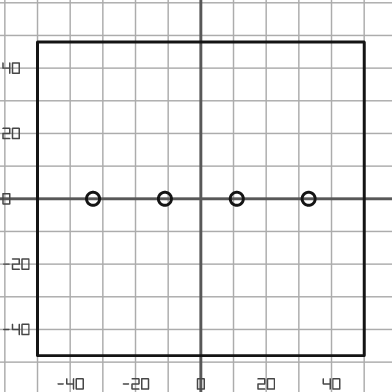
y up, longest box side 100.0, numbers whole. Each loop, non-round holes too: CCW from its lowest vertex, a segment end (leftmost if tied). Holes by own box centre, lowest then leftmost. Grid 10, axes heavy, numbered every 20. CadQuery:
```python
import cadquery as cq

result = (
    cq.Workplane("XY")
    .moveTo(-50.0, -48.0)
    .lineTo(50.0, -48.0)
    .lineTo(50.0, 48.0)
    .lineTo(-50.0, 48.0)
    .close()
    .moveTo(-33.0, 0.0)
    .circle(2.0)
    .moveTo(-11.0, 0.0)
    .circle(2.0)
    .moveTo(11.0, 0.0)
    .circle(2.0)
    .moveTo(33.0, 0.0)
    .circle(2.0)
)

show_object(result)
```